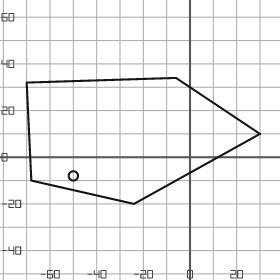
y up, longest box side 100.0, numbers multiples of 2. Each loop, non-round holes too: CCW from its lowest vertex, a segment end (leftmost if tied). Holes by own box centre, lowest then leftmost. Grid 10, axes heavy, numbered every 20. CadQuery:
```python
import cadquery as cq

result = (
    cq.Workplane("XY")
    .moveTo(-24.0, -20.0)
    .lineTo(30.0, 10.0)
    .lineTo(-6.0, 34.0)
    .lineTo(-70.0, 32.0)
    .lineTo(-68.0, -10.0)
    .close()
    .moveTo(-50.0, -8.0)
    .circle(2.0)
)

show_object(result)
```